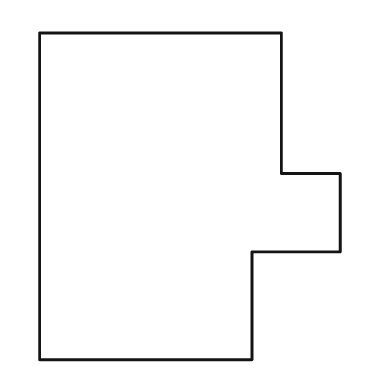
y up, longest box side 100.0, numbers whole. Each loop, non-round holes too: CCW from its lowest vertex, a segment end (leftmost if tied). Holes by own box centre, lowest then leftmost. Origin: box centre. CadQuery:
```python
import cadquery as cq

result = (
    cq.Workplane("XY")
    .moveTo(-46.0, -50.0)
    .lineTo(19.0, -50.0)
    .lineTo(19.0, -17.0)
    .lineTo(46.0, -17.0)
    .lineTo(46.0, 7.0)
    .lineTo(28.0, 7.0)
    .lineTo(28.0, 50.0)
    .lineTo(-46.0, 50.0)
    .close()
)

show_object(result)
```